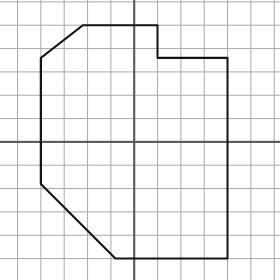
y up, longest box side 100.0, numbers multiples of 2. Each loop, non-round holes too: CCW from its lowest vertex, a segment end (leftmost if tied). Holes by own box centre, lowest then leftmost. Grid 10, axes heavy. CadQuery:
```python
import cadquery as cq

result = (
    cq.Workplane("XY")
    .moveTo(-8.0, -50.0)
    .lineTo(40.0, -50.0)
    .lineTo(40.0, 36.0)
    .lineTo(10.0, 36.0)
    .lineTo(10.0, 50.0)
    .lineTo(-22.0, 50.0)
    .lineTo(-40.0, 36.0)
    .lineTo(-40.0, -18.0)
    .close()
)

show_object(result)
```